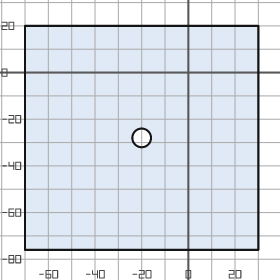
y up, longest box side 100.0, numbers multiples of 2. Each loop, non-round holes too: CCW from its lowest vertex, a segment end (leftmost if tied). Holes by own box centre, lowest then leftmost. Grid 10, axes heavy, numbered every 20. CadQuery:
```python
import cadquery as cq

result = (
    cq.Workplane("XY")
    .moveTo(-70.0, -76.0)
    .lineTo(30.0, -76.0)
    .lineTo(30.0, 20.0)
    .lineTo(-70.0, 20.0)
    .close()
    .moveTo(-20.0, -28.0)
    .circle(4.0)
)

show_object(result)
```